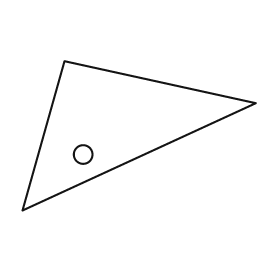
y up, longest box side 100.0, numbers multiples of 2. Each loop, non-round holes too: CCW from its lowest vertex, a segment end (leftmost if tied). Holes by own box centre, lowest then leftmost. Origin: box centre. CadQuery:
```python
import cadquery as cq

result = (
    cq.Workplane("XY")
    .moveTo(-50.0, -32.0)
    .lineTo(50.0, 14.0)
    .lineTo(-32.0, 32.0)
    .close()
    .moveTo(-24.0, -8.0)
    .circle(4.0)
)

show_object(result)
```